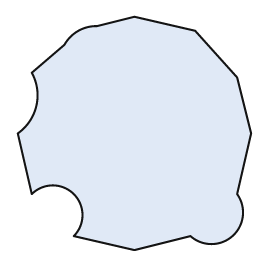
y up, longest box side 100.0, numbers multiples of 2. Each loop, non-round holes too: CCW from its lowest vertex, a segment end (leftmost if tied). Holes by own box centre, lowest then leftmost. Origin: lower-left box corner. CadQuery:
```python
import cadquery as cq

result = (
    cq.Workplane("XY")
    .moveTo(50.0, 0.0)
    .lineTo(74.0, 6.0)
    .threePointArc((92.0, 6.0), (94.0, 24.0))
    .lineTo(100.0, 50.0)
    .lineTo(94.0, 74.0)
    .lineTo(76.0, 94.0)
    .lineTo(50.0, 100.0)
    .lineTo(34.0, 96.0)
    .threePointArc((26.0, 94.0), (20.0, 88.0))
    .lineTo(6.0, 76.0)
    .threePointArc((8.0, 62.0), (0.0, 50.0))
    .lineTo(6.0, 24.0)
    .threePointArc((24.0, 24.0), (24.0, 6.0))
    .close()
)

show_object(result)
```